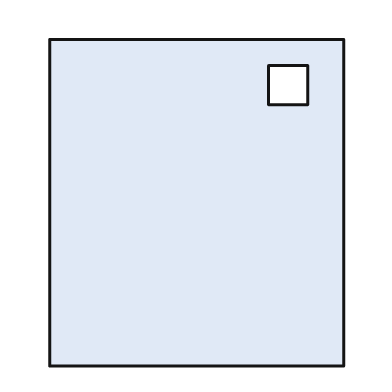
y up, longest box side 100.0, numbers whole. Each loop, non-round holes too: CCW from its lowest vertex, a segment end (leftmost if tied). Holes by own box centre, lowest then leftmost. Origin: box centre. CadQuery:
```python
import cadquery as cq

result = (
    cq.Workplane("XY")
    .moveTo(-45.0, -50.0)
    .lineTo(45.0, -50.0)
    .lineTo(45.0, 50.0)
    .lineTo(-45.0, 50.0)
    .close()
    .moveTo(22.0, 30.0)
    .lineTo(34.0, 30.0)
    .lineTo(34.0, 42.0)
    .lineTo(22.0, 42.0)
    .close()
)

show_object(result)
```